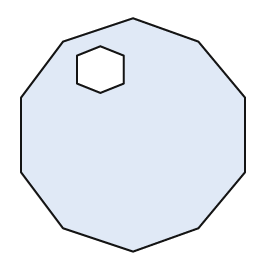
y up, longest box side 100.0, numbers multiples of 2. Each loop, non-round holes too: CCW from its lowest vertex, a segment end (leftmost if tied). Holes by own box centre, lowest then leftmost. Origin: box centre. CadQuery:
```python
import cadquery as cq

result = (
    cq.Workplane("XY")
    .moveTo(0.0, -50.0)
    .lineTo(28.0, -40.0)
    .lineTo(48.0, -16.0)
    .lineTo(48.0, 16.0)
    .lineTo(28.0, 40.0)
    .lineTo(0.0, 50.0)
    .lineTo(-30.0, 40.0)
    .lineTo(-48.0, 16.0)
    .lineTo(-48.0, -16.0)
    .lineTo(-30.0, -40.0)
    .close()
    .moveTo(-14.0, 18.0)
    .lineTo(-4.0, 22.0)
    .lineTo(-4.0, 34.0)
    .lineTo(-14.0, 38.0)
    .lineTo(-24.0, 34.0)
    .lineTo(-24.0, 22.0)
    .close()
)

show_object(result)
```